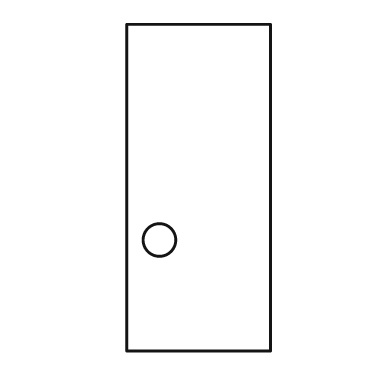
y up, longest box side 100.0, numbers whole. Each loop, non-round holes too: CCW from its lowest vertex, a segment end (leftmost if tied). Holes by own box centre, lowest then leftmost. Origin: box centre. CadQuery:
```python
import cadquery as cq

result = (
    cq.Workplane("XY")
    .moveTo(-22.0, -50.0)
    .lineTo(22.0, -50.0)
    .lineTo(22.0, 50.0)
    .lineTo(-22.0, 50.0)
    .close()
    .moveTo(-12.0, -16.0)
    .circle(5.0)
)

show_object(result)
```